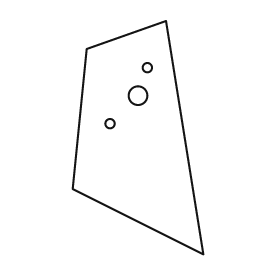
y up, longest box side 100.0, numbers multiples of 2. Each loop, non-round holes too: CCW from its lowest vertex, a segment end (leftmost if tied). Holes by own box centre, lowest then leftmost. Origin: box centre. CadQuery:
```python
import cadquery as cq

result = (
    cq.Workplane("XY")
    .moveTo(28.0, -50.0)
    .lineTo(12.0, 50.0)
    .lineTo(-22.0, 38.0)
    .lineTo(-28.0, -22.0)
    .close()
    .moveTo(-12.0, 6.0)
    .circle(2.0)
    .moveTo(0.0, 18.0)
    .circle(4.0)
    .moveTo(4.0, 30.0)
    .circle(2.0)
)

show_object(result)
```